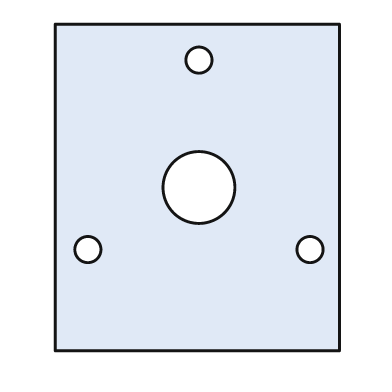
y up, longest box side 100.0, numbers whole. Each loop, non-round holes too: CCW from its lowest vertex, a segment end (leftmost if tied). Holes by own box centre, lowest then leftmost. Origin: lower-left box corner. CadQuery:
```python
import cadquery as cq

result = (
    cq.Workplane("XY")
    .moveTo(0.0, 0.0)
    .lineTo(87.0, 0.0)
    .lineTo(87.0, 100.0)
    .lineTo(0.0, 100.0)
    .close()
    .moveTo(10.0, 31.0)
    .circle(4.0)
    .moveTo(78.0, 31.0)
    .circle(4.0)
    .moveTo(44.0, 50.0)
    .circle(11.0)
    .moveTo(44.0, 89.0)
    .circle(4.0)
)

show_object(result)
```